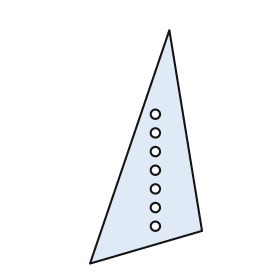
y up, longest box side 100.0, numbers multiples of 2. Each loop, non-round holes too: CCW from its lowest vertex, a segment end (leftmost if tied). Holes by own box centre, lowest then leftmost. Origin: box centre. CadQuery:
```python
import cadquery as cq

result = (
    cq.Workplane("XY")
    .moveTo(-24.0, -50.0)
    .lineTo(24.0, -36.0)
    .lineTo(10.0, 50.0)
    .close()
    .moveTo(4.0, -34.0)
    .circle(2.0)
    .moveTo(4.0, -26.0)
    .circle(2.0)
    .moveTo(4.0, -18.0)
    .circle(2.0)
    .moveTo(4.0, -10.0)
    .circle(2.0)
    .moveTo(4.0, -2.0)
    .circle(2.0)
    .moveTo(4.0, 6.0)
    .circle(2.0)
    .moveTo(4.0, 14.0)
    .circle(2.0)
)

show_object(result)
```